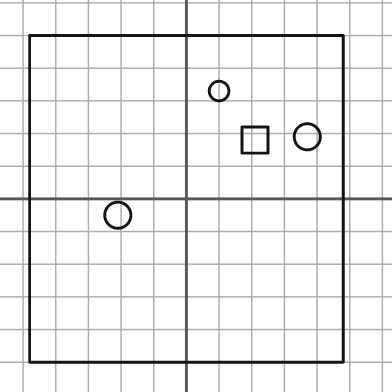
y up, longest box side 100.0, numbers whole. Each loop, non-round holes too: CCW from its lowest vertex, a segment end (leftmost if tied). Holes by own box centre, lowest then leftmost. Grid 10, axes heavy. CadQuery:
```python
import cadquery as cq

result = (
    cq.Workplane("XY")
    .moveTo(-48.0, -50.0)
    .lineTo(48.0, -50.0)
    .lineTo(48.0, 50.0)
    .lineTo(-48.0, 50.0)
    .close()
    .moveTo(-21.0, -5.0)
    .circle(4.0)
    .moveTo(17.0, 14.0)
    .lineTo(25.0, 14.0)
    .lineTo(25.0, 22.0)
    .lineTo(17.0, 22.0)
    .close()
    .moveTo(37.0, 19.0)
    .circle(4.0)
    .moveTo(10.0, 33.0)
    .circle(3.0)
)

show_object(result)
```